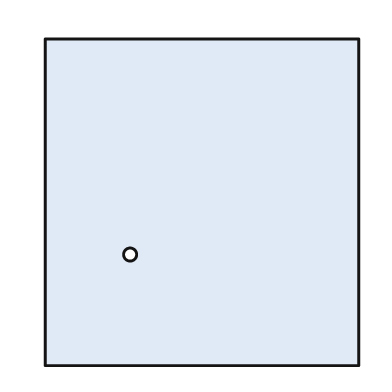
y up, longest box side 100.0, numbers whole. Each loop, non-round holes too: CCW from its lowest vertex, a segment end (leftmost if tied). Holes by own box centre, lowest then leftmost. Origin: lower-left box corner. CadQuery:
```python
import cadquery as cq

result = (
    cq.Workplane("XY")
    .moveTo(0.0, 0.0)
    .lineTo(96.0, 0.0)
    .lineTo(96.0, 100.0)
    .lineTo(0.0, 100.0)
    .close()
    .moveTo(26.0, 34.0)
    .circle(2.0)
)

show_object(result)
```